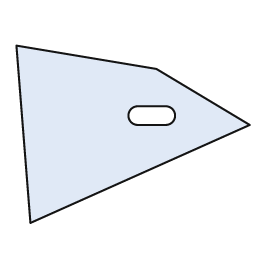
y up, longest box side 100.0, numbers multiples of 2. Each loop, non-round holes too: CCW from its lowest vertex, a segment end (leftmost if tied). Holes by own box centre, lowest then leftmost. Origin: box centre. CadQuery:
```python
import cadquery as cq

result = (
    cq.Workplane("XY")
    .moveTo(-44.0, -38.0)
    .lineTo(50.0, 4.0)
    .lineTo(10.0, 28.0)
    .lineTo(-50.0, 38.0)
    .close()
    .moveTo(2.0, 4.0)
    .lineTo(14.0, 4.0)
    .threePointArc((18.0, 8.0), (14.0, 12.0))
    .lineTo(2.0, 12.0)
    .threePointArc((-2.0, 8.0), (2.0, 4.0))
    .close()
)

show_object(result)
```